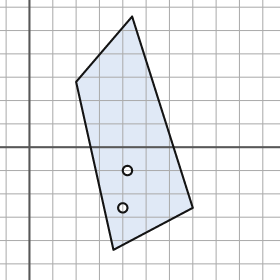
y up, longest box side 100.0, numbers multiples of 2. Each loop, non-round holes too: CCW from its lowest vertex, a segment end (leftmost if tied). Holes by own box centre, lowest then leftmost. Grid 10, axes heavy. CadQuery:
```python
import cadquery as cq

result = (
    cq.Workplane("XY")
    .moveTo(36.0, -44.0)
    .lineTo(70.0, -26.0)
    .lineTo(44.0, 56.0)
    .lineTo(20.0, 28.0)
    .close()
    .moveTo(40.0, -26.0)
    .circle(2.0)
    .moveTo(42.0, -10.0)
    .circle(2.0)
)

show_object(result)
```